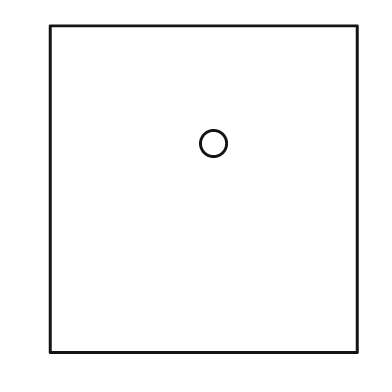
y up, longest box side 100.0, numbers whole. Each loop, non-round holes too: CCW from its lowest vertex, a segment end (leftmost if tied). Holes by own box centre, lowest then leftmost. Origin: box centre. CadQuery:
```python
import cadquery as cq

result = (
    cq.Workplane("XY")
    .moveTo(-47.0, -50.0)
    .lineTo(47.0, -50.0)
    .lineTo(47.0, 50.0)
    .lineTo(-47.0, 50.0)
    .close()
    .moveTo(3.0, 14.0)
    .circle(4.0)
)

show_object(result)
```